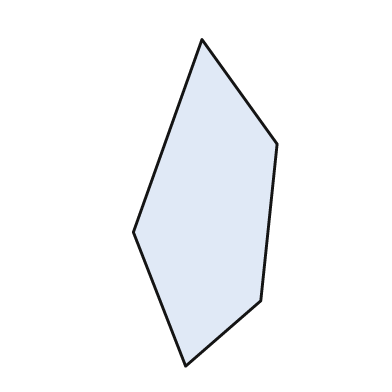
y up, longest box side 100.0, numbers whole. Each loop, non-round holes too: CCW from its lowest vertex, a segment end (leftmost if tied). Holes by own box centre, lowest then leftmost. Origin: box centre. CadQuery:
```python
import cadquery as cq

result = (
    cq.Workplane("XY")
    .moveTo(-6.0, -50.0)
    .lineTo(17.0, -30.0)
    .lineTo(22.0, 18.0)
    .lineTo(-1.0, 50.0)
    .lineTo(-22.0, -9.0)
    .close()
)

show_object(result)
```